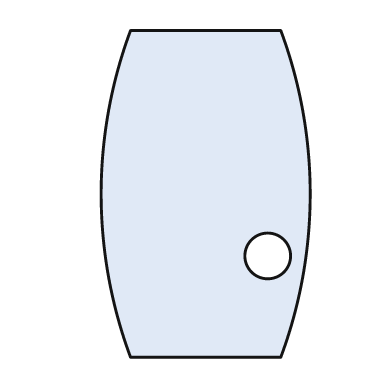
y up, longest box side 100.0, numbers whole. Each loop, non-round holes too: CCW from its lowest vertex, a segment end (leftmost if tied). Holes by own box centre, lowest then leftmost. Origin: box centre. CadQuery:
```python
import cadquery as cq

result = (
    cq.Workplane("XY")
    .moveTo(-23.0, -50.0)
    .lineTo(23.0, -50.0)
    .threePointArc((32.0, 0.0), (23.0, 50.0))
    .lineTo(-23.0, 50.0)
    .threePointArc((-32.0, 0.0), (-23.0, -50.0))
    .close()
    .moveTo(19.0, -19.0)
    .circle(7.0)
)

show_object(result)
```